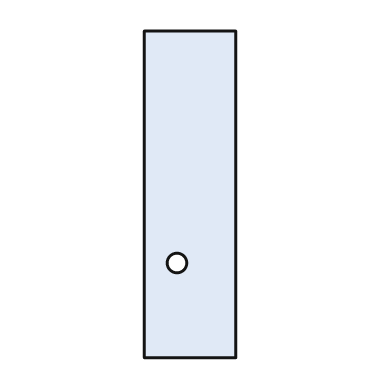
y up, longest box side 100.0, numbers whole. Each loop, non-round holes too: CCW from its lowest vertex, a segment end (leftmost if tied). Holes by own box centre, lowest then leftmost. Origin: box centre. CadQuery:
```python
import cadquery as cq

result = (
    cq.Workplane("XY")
    .moveTo(-14.0, -50.0)
    .lineTo(14.0, -50.0)
    .lineTo(14.0, 50.0)
    .lineTo(-14.0, 50.0)
    .close()
    .moveTo(-4.0, -21.0)
    .circle(3.0)
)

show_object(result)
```